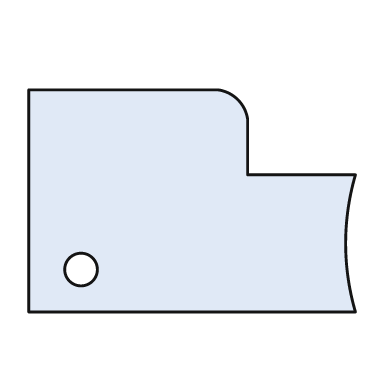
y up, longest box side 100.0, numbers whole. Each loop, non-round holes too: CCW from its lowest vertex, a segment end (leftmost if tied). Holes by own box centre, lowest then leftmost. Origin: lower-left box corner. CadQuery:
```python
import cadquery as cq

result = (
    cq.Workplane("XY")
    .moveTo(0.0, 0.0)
    .lineTo(100.0, 0.0)
    .threePointArc((97.0, 21.0), (100.0, 42.0))
    .lineTo(67.0, 42.0)
    .lineTo(67.0, 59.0)
    .threePointArc((64.0, 65.0), (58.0, 68.0))
    .lineTo(0.0, 68.0)
    .close()
    .moveTo(16.0, 13.0)
    .circle(5.0)
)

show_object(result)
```